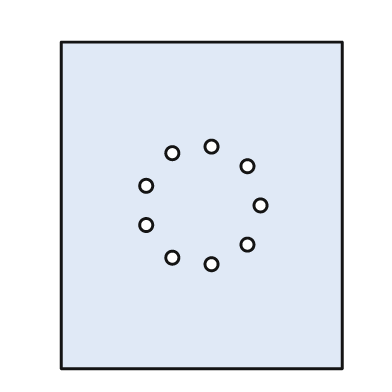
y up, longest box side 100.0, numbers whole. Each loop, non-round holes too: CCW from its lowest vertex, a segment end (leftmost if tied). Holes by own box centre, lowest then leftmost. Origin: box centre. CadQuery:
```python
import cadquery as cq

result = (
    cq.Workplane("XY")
    .moveTo(-43.0, -50.0)
    .lineTo(43.0, -50.0)
    .lineTo(43.0, 50.0)
    .lineTo(-43.0, 50.0)
    .close()
    .moveTo(3.0, -18.0)
    .circle(2.0)
    .moveTo(-9.0, -16.0)
    .circle(2.0)
    .moveTo(14.0, -12.0)
    .circle(2.0)
    .moveTo(-17.0, -6.0)
    .circle(2.0)
    .moveTo(18.0, 0.0)
    .circle(2.0)
    .moveTo(-17.0, 6.0)
    .circle(2.0)
    .moveTo(14.0, 12.0)
    .circle(2.0)
    .moveTo(-9.0, 16.0)
    .circle(2.0)
    .moveTo(3.0, 18.0)
    .circle(2.0)
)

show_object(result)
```